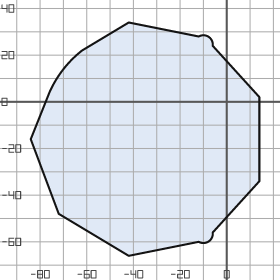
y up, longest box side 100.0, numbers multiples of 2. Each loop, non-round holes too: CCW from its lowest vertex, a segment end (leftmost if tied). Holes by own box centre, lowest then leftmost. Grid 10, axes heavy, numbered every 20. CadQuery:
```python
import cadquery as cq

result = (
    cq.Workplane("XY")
    .moveTo(-42.0, -66.0)
    .lineTo(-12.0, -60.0)
    .threePointArc((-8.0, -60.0), (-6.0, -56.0))
    .lineTo(14.0, -34.0)
    .lineTo(14.0, 2.0)
    .lineTo(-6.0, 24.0)
    .threePointArc((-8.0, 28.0), (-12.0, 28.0))
    .lineTo(-42.0, 34.0)
    .lineTo(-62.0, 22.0)
    .threePointArc((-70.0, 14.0), (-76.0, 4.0))
    .lineTo(-84.0, -16.0)
    .lineTo(-72.0, -48.0)
    .close()
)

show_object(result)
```